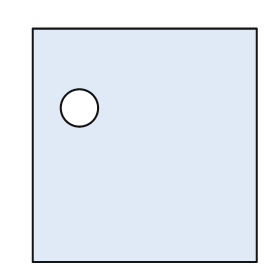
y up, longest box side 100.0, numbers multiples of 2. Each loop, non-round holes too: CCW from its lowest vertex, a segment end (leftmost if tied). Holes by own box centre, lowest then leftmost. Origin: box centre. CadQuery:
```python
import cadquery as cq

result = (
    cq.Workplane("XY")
    .moveTo(-48.0, -50.0)
    .lineTo(48.0, -50.0)
    .lineTo(48.0, 50.0)
    .lineTo(-48.0, 50.0)
    .close()
    .moveTo(-28.0, 16.0)
    .circle(8.0)
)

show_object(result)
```